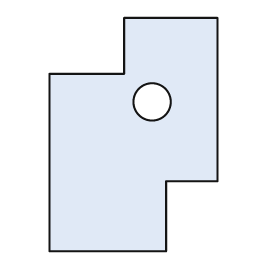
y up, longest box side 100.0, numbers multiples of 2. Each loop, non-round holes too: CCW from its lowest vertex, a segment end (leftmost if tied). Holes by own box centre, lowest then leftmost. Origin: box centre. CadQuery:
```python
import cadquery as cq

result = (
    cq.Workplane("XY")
    .moveTo(-36.0, -50.0)
    .lineTo(14.0, -50.0)
    .lineTo(14.0, -20.0)
    .lineTo(36.0, -20.0)
    .lineTo(36.0, 50.0)
    .lineTo(-4.0, 50.0)
    .lineTo(-4.0, 26.0)
    .lineTo(-36.0, 26.0)
    .close()
    .moveTo(8.0, 14.0)
    .circle(8.0)
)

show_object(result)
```